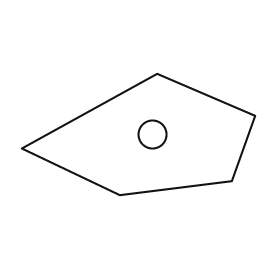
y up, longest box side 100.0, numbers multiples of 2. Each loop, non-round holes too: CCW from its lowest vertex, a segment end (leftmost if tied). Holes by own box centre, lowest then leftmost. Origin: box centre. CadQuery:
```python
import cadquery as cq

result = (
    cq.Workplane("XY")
    .moveTo(-8.0, -26.0)
    .lineTo(40.0, -20.0)
    .lineTo(50.0, 8.0)
    .lineTo(8.0, 26.0)
    .lineTo(-50.0, -6.0)
    .close()
    .moveTo(6.0, 0.0)
    .circle(6.0)
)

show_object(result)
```